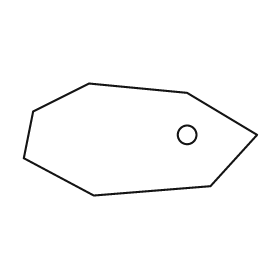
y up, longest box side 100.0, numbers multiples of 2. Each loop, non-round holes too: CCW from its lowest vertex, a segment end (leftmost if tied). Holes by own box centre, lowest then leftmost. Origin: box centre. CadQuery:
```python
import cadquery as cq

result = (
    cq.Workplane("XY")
    .moveTo(-20.0, -24.0)
    .lineTo(30.0, -20.0)
    .lineTo(50.0, 2.0)
    .lineTo(20.0, 20.0)
    .lineTo(-22.0, 24.0)
    .lineTo(-46.0, 12.0)
    .lineTo(-50.0, -8.0)
    .close()
    .moveTo(20.0, 2.0)
    .circle(4.0)
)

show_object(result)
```